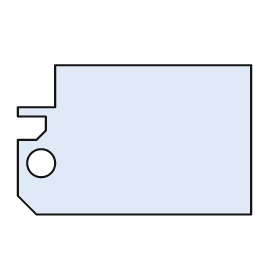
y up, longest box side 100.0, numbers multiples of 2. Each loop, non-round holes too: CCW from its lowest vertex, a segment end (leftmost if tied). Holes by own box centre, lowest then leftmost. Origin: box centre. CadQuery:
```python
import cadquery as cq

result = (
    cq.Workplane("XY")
    .moveTo(-42.0, -32.0)
    .lineTo(50.0, -32.0)
    .lineTo(50.0, 32.0)
    .lineTo(-34.0, 32.0)
    .lineTo(-34.0, 14.0)
    .lineTo(-50.0, 14.0)
    .lineTo(-50.0, 10.0)
    .lineTo(-38.0, 10.0)
    .lineTo(-38.0, 4.0)
    .lineTo(-42.0, 0.0)
    .lineTo(-50.0, 0.0)
    .lineTo(-50.0, -24.0)
    .close()
    .moveTo(-40.0, -10.0)
    .circle(6.0)
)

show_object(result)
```